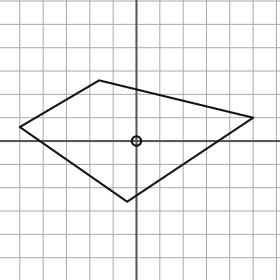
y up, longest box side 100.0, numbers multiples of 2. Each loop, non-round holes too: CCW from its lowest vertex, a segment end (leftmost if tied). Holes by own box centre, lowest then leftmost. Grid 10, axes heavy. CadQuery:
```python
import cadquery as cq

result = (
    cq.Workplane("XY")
    .moveTo(-4.0, -26.0)
    .lineTo(50.0, 10.0)
    .lineTo(-16.0, 26.0)
    .lineTo(-50.0, 6.0)
    .close()
    .moveTo(0.0, 0.0)
    .circle(2.0)
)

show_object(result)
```